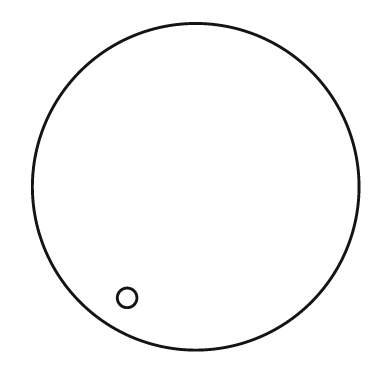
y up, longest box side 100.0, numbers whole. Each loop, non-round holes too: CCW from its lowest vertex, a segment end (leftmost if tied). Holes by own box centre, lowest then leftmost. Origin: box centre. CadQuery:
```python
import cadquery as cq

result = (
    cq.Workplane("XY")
    .moveTo(0.0, 0.0)
    .circle(50.0)
    .moveTo(-21.0, -34.0)
    .circle(3.0)
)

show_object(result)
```